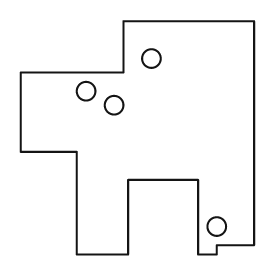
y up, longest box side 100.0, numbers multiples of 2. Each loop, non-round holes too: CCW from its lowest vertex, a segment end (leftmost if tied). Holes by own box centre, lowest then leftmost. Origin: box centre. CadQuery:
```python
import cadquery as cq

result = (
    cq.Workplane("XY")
    .moveTo(-26.0, -50.0)
    .lineTo(-4.0, -50.0)
    .lineTo(-4.0, -18.0)
    .lineTo(26.0, -18.0)
    .lineTo(26.0, -50.0)
    .lineTo(34.0, -50.0)
    .lineTo(34.0, -46.0)
    .lineTo(50.0, -46.0)
    .lineTo(50.0, 50.0)
    .lineTo(-6.0, 50.0)
    .lineTo(-6.0, 28.0)
    .lineTo(-50.0, 28.0)
    .lineTo(-50.0, -6.0)
    .lineTo(-26.0, -6.0)
    .close()
    .moveTo(34.0, -38.0)
    .circle(4.0)
    .moveTo(-10.0, 14.0)
    .circle(4.0)
    .moveTo(-22.0, 20.0)
    .circle(4.0)
    .moveTo(6.0, 34.0)
    .circle(4.0)
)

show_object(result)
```